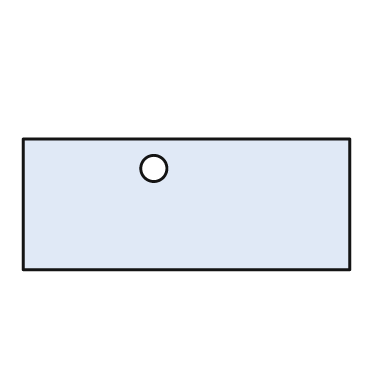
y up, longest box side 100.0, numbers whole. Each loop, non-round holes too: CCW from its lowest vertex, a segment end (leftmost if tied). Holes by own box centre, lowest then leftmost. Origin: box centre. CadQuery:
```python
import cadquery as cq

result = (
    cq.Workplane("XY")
    .moveTo(-50.0, -20.0)
    .lineTo(50.0, -20.0)
    .lineTo(50.0, 20.0)
    .lineTo(-50.0, 20.0)
    .close()
    .moveTo(-10.0, 11.0)
    .circle(4.0)
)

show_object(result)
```